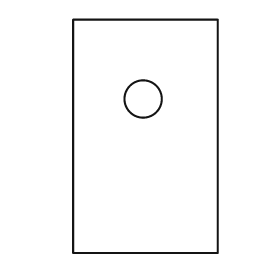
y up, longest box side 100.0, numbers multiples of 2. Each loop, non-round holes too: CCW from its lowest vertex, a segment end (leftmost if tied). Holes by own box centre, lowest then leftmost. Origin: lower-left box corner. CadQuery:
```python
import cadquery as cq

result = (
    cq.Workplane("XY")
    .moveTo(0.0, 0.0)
    .lineTo(62.0, 0.0)
    .lineTo(62.0, 100.0)
    .lineTo(0.0, 100.0)
    .close()
    .moveTo(30.0, 66.0)
    .circle(8.0)
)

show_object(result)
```